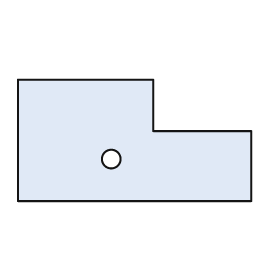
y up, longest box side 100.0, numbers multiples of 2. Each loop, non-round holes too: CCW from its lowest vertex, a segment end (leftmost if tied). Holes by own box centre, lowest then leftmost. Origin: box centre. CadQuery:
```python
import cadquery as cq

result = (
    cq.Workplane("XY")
    .moveTo(-50.0, -26.0)
    .lineTo(50.0, -26.0)
    .lineTo(50.0, 4.0)
    .lineTo(8.0, 4.0)
    .lineTo(8.0, 26.0)
    .lineTo(-50.0, 26.0)
    .close()
    .moveTo(-10.0, -8.0)
    .circle(4.0)
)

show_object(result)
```